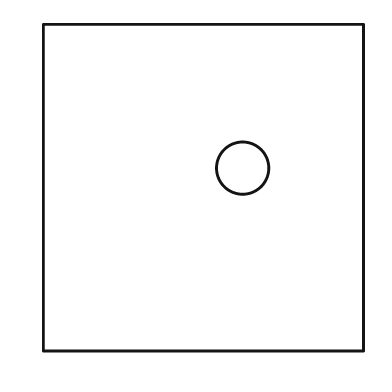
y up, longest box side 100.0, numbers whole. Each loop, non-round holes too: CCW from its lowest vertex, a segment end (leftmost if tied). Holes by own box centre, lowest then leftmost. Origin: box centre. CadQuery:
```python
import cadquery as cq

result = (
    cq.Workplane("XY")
    .moveTo(-49.0, -50.0)
    .lineTo(49.0, -50.0)
    .lineTo(49.0, 50.0)
    .lineTo(-49.0, 50.0)
    .close()
    .moveTo(12.0, 6.0)
    .circle(8.0)
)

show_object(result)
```